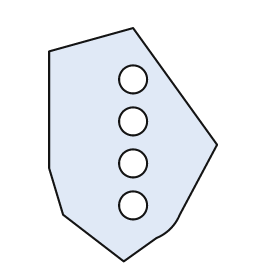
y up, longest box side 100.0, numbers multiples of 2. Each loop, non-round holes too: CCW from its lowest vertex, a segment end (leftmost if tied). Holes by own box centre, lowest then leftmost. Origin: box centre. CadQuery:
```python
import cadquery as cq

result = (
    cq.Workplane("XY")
    .moveTo(-4.0, -50.0)
    .lineTo(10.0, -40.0)
    .threePointArc((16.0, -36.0), (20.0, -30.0))
    .lineTo(36.0, 0.0)
    .lineTo(0.0, 50.0)
    .lineTo(-36.0, 40.0)
    .lineTo(-36.0, -10.0)
    .lineTo(-30.0, -30.0)
    .close()
    .moveTo(0.0, -26.0)
    .circle(6.0)
    .moveTo(0.0, -8.0)
    .circle(6.0)
    .moveTo(0.0, 10.0)
    .circle(6.0)
    .moveTo(0.0, 28.0)
    .circle(6.0)
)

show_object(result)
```